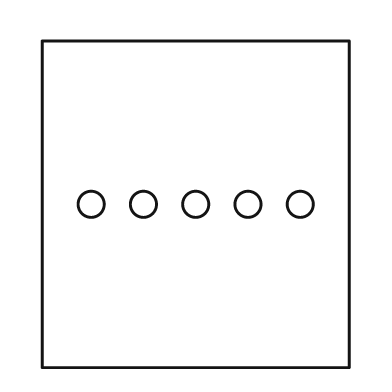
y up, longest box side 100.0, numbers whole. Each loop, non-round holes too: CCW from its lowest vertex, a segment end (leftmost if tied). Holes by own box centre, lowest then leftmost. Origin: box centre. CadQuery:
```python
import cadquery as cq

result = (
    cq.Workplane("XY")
    .moveTo(-47.0, -50.0)
    .lineTo(47.0, -50.0)
    .lineTo(47.0, 50.0)
    .lineTo(-47.0, 50.0)
    .close()
    .moveTo(-32.0, 0.0)
    .circle(4.0)
    .moveTo(-16.0, 0.0)
    .circle(4.0)
    .moveTo(0.0, 0.0)
    .circle(4.0)
    .moveTo(16.0, 0.0)
    .circle(4.0)
    .moveTo(32.0, 0.0)
    .circle(4.0)
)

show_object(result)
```